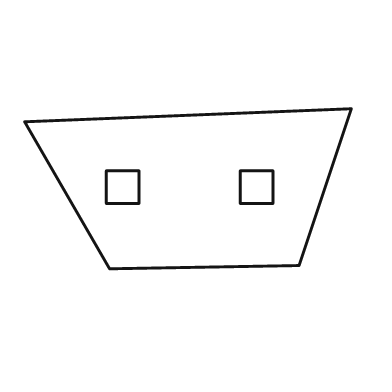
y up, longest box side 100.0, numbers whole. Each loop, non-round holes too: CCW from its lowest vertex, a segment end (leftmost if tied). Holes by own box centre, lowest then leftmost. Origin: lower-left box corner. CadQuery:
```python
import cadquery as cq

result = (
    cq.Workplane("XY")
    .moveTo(26.0, 0.0)
    .lineTo(84.0, 1.0)
    .lineTo(100.0, 49.0)
    .lineTo(0.0, 45.0)
    .close()
    .moveTo(25.0, 20.0)
    .lineTo(35.0, 20.0)
    .lineTo(35.0, 30.0)
    .lineTo(25.0, 30.0)
    .close()
    .moveTo(66.0, 20.0)
    .lineTo(76.0, 20.0)
    .lineTo(76.0, 30.0)
    .lineTo(66.0, 30.0)
    .close()
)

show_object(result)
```